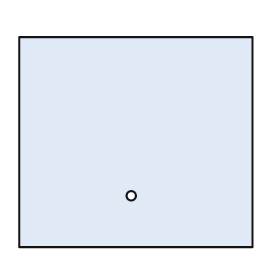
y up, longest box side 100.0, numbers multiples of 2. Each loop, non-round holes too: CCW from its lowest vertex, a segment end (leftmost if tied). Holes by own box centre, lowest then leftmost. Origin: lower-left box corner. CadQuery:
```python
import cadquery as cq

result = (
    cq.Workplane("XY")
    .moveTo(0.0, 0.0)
    .lineTo(100.0, 0.0)
    .lineTo(100.0, 90.0)
    .lineTo(0.0, 90.0)
    .close()
    .moveTo(48.0, 22.0)
    .circle(2.0)
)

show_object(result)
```